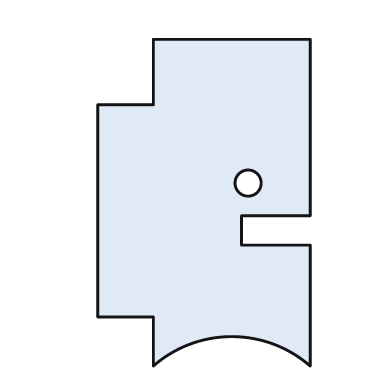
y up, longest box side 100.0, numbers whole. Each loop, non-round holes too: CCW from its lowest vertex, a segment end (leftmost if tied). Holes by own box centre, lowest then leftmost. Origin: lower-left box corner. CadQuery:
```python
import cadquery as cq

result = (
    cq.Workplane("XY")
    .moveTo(17.0, 0.0)
    .threePointArc((41.0, 9.0), (65.0, 0.0))
    .lineTo(65.0, 37.0)
    .lineTo(44.0, 37.0)
    .lineTo(44.0, 46.0)
    .lineTo(65.0, 46.0)
    .lineTo(65.0, 100.0)
    .lineTo(17.0, 100.0)
    .lineTo(17.0, 80.0)
    .lineTo(0.0, 80.0)
    .lineTo(0.0, 15.0)
    .lineTo(17.0, 15.0)
    .close()
    .moveTo(46.0, 56.0)
    .circle(4.0)
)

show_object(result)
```